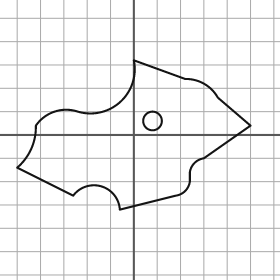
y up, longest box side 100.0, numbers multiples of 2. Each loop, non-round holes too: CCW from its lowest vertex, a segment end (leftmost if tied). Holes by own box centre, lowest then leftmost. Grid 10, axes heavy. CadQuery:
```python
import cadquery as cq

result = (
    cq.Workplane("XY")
    .moveTo(-6.0, -32.0)
    .lineTo(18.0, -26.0)
    .threePointArc((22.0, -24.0), (24.0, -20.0))
    .lineTo(24.0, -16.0)
    .threePointArc((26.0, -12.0), (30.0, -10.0))
    .lineTo(50.0, 4.0)
    .lineTo(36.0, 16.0)
    .threePointArc((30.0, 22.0), (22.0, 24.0))
    .lineTo(0.0, 32.0)
    .threePointArc((-6.0, 14.0), (-24.0, 10.0))
    .threePointArc((-34.0, 10.0), (-42.0, 4.0))
    .threePointArc((-44.0, -6.0), (-50.0, -14.0))
    .lineTo(-26.0, -26.0)
    .threePointArc((-14.0, -22.0), (-6.0, -32.0))
    .close()
    .moveTo(8.0, 6.0)
    .circle(4.0)
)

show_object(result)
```